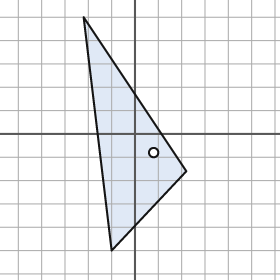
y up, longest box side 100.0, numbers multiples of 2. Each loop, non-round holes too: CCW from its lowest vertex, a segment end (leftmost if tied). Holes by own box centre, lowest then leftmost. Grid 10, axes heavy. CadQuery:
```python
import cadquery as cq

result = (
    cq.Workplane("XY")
    .moveTo(-10.0, -50.0)
    .lineTo(22.0, -16.0)
    .lineTo(-22.0, 50.0)
    .close()
    .moveTo(8.0, -8.0)
    .circle(2.0)
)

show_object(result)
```